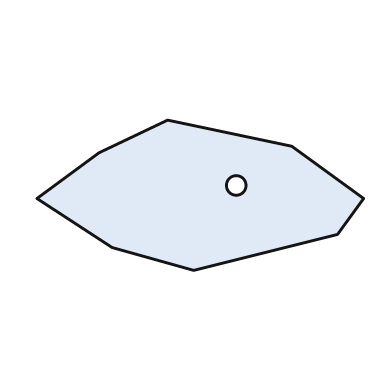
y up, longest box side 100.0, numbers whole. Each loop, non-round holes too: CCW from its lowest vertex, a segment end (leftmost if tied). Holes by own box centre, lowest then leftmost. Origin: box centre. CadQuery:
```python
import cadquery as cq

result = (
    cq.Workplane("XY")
    .moveTo(-2.0, -23.0)
    .lineTo(42.0, -12.0)
    .lineTo(50.0, -1.0)
    .lineTo(28.0, 15.0)
    .lineTo(-10.0, 23.0)
    .lineTo(-31.0, 13.0)
    .lineTo(-50.0, -1.0)
    .lineTo(-27.0, -16.0)
    .close()
    .moveTo(11.0, 3.0)
    .circle(3.0)
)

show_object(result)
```